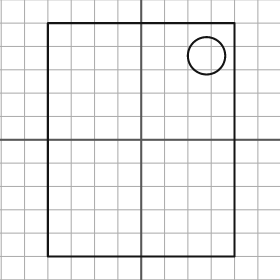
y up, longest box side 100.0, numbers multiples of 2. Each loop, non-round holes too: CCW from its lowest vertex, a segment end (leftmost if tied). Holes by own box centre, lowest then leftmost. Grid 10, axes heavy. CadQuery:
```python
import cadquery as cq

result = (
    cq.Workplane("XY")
    .moveTo(-40.0, -50.0)
    .lineTo(40.0, -50.0)
    .lineTo(40.0, 50.0)
    .lineTo(-40.0, 50.0)
    .close()
    .moveTo(28.0, 36.0)
    .circle(8.0)
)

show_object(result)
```